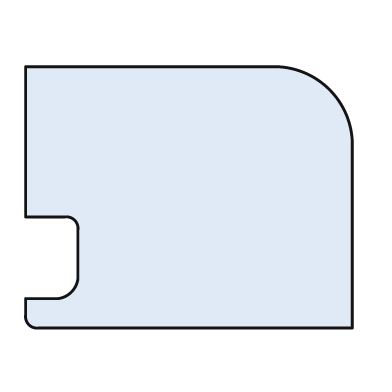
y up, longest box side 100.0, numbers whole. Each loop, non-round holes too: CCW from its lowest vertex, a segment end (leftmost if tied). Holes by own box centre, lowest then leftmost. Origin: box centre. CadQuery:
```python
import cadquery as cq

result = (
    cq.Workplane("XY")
    .moveTo(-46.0, -40.0)
    .lineTo(50.0, -40.0)
    .lineTo(50.0, 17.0)
    .threePointArc((43.0, 33.0), (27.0, 40.0))
    .lineTo(-50.0, 40.0)
    .lineTo(-50.0, -6.0)
    .lineTo(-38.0, -6.0)
    .threePointArc((-35.0, -7.0), (-34.0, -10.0))
    .lineTo(-34.0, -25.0)
    .threePointArc((-36.0, -29.0), (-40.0, -31.0))
    .lineTo(-50.0, -31.0)
    .lineTo(-50.0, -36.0)
    .threePointArc((-49.0, -39.0), (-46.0, -40.0))
    .close()
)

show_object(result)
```